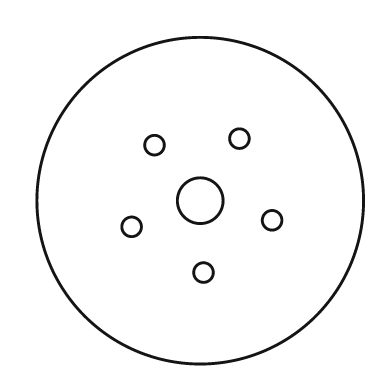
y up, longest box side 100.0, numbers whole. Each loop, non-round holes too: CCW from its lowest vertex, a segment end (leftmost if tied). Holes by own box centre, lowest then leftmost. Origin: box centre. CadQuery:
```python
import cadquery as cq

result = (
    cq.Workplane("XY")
    .moveTo(0.0, 0.0)
    .circle(50.0)
    .moveTo(1.0, -22.0)
    .circle(3.0)
    .moveTo(-21.0, -8.0)
    .circle(3.0)
    .moveTo(22.0, -6.0)
    .circle(3.0)
    .moveTo(0.0, 0.0)
    .circle(7.0)
    .moveTo(-14.0, 17.0)
    .circle(3.0)
    .moveTo(12.0, 19.0)
    .circle(3.0)
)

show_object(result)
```